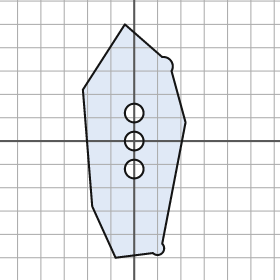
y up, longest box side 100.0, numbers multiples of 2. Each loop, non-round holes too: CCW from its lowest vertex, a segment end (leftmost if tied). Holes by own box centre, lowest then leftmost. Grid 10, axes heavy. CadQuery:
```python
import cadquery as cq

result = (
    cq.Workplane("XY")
    .moveTo(-8.0, -50.0)
    .lineTo(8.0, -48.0)
    .threePointArc((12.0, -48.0), (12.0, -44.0))
    .lineTo(22.0, 8.0)
    .lineTo(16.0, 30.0)
    .threePointArc((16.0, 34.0), (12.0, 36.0))
    .lineTo(-4.0, 50.0)
    .lineTo(-22.0, 22.0)
    .lineTo(-18.0, -28.0)
    .close()
    .moveTo(0.0, -12.0)
    .circle(4.0)
    .moveTo(0.0, 0.0)
    .circle(4.0)
    .moveTo(0.0, 12.0)
    .circle(4.0)
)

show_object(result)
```